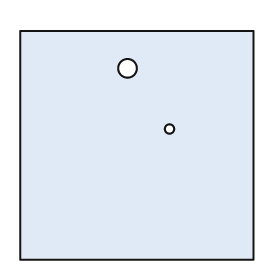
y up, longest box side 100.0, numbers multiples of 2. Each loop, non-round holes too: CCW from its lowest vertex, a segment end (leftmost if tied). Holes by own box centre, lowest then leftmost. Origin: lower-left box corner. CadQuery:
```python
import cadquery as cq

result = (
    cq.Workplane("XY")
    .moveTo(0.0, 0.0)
    .lineTo(100.0, 0.0)
    .lineTo(100.0, 98.0)
    .lineTo(0.0, 98.0)
    .close()
    .moveTo(64.0, 56.0)
    .circle(2.0)
    .moveTo(46.0, 82.0)
    .circle(4.0)
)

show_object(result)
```